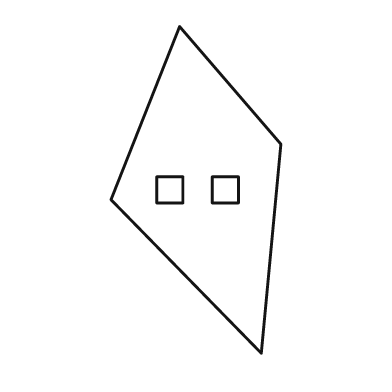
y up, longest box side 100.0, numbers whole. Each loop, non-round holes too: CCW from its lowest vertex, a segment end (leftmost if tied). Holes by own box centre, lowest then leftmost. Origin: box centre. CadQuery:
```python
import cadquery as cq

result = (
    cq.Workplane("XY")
    .moveTo(20.0, -50.0)
    .lineTo(26.0, 14.0)
    .lineTo(-5.0, 50.0)
    .lineTo(-26.0, -3.0)
    .close()
    .moveTo(-12.0, -4.0)
    .lineTo(-4.0, -4.0)
    .lineTo(-4.0, 4.0)
    .lineTo(-12.0, 4.0)
    .close()
    .moveTo(5.0, -4.0)
    .lineTo(13.0, -4.0)
    .lineTo(13.0, 4.0)
    .lineTo(5.0, 4.0)
    .close()
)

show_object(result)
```